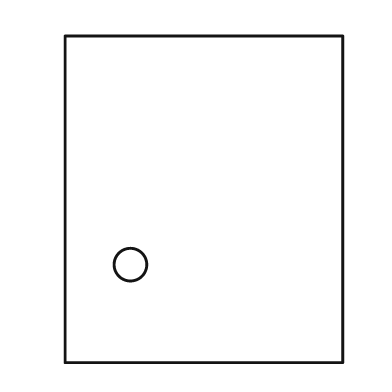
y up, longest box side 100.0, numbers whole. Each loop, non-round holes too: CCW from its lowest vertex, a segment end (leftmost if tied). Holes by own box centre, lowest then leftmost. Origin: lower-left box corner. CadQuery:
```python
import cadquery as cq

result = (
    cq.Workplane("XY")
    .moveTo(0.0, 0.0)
    .lineTo(85.0, 0.0)
    .lineTo(85.0, 100.0)
    .lineTo(0.0, 100.0)
    .close()
    .moveTo(20.0, 30.0)
    .circle(5.0)
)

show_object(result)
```